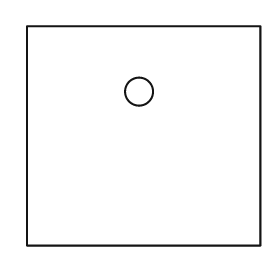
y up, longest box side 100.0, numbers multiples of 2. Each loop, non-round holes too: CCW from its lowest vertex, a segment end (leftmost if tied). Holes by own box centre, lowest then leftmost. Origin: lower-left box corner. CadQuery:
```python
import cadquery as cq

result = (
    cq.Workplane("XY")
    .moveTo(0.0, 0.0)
    .lineTo(100.0, 0.0)
    .lineTo(100.0, 94.0)
    .lineTo(0.0, 94.0)
    .close()
    .moveTo(48.0, 66.0)
    .circle(6.0)
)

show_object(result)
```